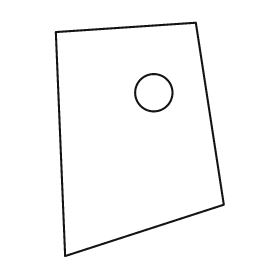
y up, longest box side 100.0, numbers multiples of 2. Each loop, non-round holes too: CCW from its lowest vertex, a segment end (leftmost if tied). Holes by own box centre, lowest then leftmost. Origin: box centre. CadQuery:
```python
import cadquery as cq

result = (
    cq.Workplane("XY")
    .moveTo(-32.0, -50.0)
    .lineTo(36.0, -28.0)
    .lineTo(24.0, 50.0)
    .lineTo(-36.0, 46.0)
    .close()
    .moveTo(6.0, 20.0)
    .circle(8.0)
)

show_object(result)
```